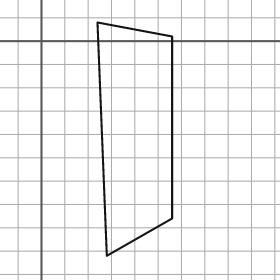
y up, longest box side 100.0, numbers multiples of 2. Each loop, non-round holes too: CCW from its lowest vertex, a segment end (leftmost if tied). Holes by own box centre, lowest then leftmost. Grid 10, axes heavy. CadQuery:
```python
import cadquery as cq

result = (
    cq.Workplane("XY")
    .moveTo(28.0, -92.0)
    .lineTo(56.0, -76.0)
    .lineTo(56.0, 2.0)
    .lineTo(24.0, 8.0)
    .close()
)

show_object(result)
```